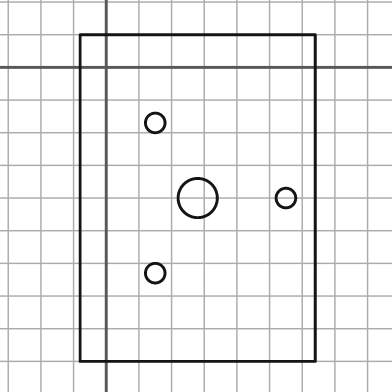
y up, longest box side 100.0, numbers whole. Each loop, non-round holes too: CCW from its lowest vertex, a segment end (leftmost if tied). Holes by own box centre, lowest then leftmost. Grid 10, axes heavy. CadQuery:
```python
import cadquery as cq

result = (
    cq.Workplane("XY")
    .moveTo(-8.0, -90.0)
    .lineTo(64.0, -90.0)
    .lineTo(64.0, 10.0)
    .lineTo(-8.0, 10.0)
    .close()
    .moveTo(15.0, -63.0)
    .circle(3.0)
    .moveTo(28.0, -40.0)
    .circle(6.0)
    .moveTo(55.0, -40.0)
    .circle(3.0)
    .moveTo(15.0, -17.0)
    .circle(3.0)
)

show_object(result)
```